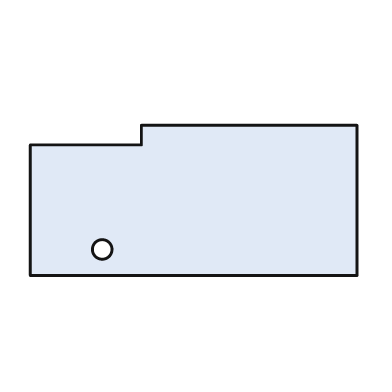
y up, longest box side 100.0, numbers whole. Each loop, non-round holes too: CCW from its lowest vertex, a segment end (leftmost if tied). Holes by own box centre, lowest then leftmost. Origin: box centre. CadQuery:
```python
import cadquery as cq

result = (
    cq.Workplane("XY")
    .moveTo(-50.0, -23.0)
    .lineTo(50.0, -23.0)
    .lineTo(50.0, 23.0)
    .lineTo(-16.0, 23.0)
    .lineTo(-16.0, 17.0)
    .lineTo(-50.0, 17.0)
    .close()
    .moveTo(-28.0, -15.0)
    .circle(3.0)
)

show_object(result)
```